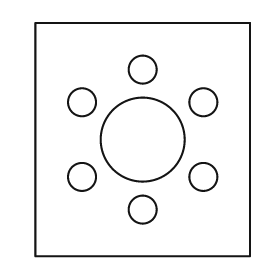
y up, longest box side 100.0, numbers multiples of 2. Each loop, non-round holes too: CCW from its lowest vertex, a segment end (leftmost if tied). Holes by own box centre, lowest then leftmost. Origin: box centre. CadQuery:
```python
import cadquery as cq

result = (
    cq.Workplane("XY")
    .moveTo(-46.0, -50.0)
    .lineTo(46.0, -50.0)
    .lineTo(46.0, 50.0)
    .lineTo(-46.0, 50.0)
    .close()
    .moveTo(0.0, -30.0)
    .circle(6.0)
    .moveTo(-26.0, -16.0)
    .circle(6.0)
    .moveTo(26.0, -16.0)
    .circle(6.0)
    .moveTo(0.0, 0.0)
    .circle(18.0)
    .moveTo(-26.0, 16.0)
    .circle(6.0)
    .moveTo(26.0, 16.0)
    .circle(6.0)
    .moveTo(0.0, 30.0)
    .circle(6.0)
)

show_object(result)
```